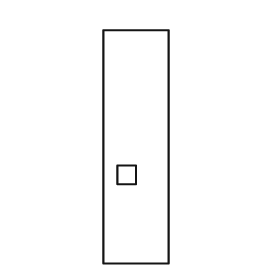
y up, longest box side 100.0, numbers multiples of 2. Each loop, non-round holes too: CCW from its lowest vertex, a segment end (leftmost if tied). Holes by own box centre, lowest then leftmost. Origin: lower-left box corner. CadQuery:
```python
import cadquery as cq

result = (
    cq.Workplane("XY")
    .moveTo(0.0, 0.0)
    .lineTo(28.0, 0.0)
    .lineTo(28.0, 100.0)
    .lineTo(0.0, 100.0)
    .close()
    .moveTo(6.0, 34.0)
    .lineTo(14.0, 34.0)
    .lineTo(14.0, 42.0)
    .lineTo(6.0, 42.0)
    .close()
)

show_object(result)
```